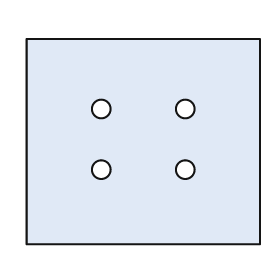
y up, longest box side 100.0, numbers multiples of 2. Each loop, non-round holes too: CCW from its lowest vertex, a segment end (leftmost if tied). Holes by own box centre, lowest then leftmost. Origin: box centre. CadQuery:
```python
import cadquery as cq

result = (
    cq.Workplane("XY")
    .moveTo(-50.0, -44.0)
    .lineTo(50.0, -44.0)
    .lineTo(50.0, 44.0)
    .lineTo(-50.0, 44.0)
    .close()
    .moveTo(-18.0, -12.0)
    .circle(4.0)
    .moveTo(18.0, -12.0)
    .circle(4.0)
    .moveTo(-18.0, 14.0)
    .circle(4.0)
    .moveTo(18.0, 14.0)
    .circle(4.0)
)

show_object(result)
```